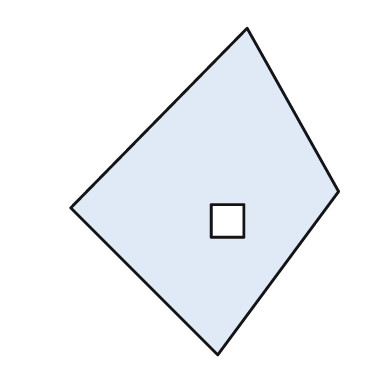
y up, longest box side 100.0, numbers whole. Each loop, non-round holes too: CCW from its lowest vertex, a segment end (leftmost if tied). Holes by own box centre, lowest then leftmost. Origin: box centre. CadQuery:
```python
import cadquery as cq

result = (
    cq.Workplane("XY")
    .moveTo(4.0, -50.0)
    .lineTo(41.0, 0.0)
    .lineTo(13.0, 50.0)
    .lineTo(-41.0, -5.0)
    .close()
    .moveTo(2.0, -14.0)
    .lineTo(12.0, -14.0)
    .lineTo(12.0, -4.0)
    .lineTo(2.0, -4.0)
    .close()
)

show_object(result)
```